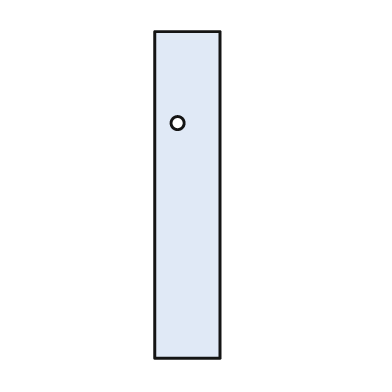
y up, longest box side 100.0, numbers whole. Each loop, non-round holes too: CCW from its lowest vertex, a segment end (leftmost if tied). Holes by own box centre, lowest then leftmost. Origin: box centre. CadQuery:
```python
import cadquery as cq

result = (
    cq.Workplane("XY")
    .moveTo(-10.0, -50.0)
    .lineTo(10.0, -50.0)
    .lineTo(10.0, 50.0)
    .lineTo(-10.0, 50.0)
    .close()
    .moveTo(-3.0, 22.0)
    .circle(2.0)
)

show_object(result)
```